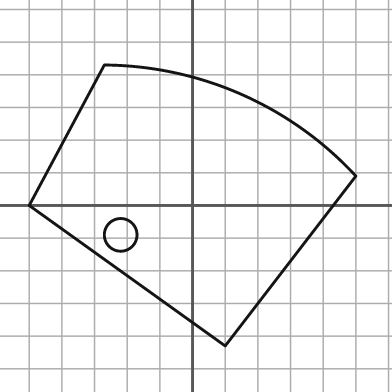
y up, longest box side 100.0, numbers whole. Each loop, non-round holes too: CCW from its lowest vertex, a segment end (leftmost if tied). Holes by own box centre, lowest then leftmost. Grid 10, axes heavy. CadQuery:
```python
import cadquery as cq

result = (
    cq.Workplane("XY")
    .moveTo(10.0, -43.0)
    .lineTo(50.0, 9.0)
    .threePointArc((15.0, 34.0), (-27.0, 43.0))
    .lineTo(-50.0, 0.0)
    .close()
    .moveTo(-22.0, -9.0)
    .circle(5.0)
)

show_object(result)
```